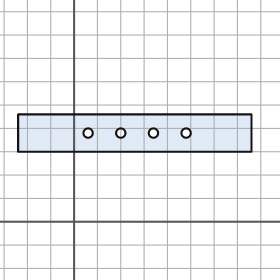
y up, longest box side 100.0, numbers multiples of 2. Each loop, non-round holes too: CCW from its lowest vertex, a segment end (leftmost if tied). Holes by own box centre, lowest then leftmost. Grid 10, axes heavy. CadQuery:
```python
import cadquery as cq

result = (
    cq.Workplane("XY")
    .moveTo(-24.0, 30.0)
    .lineTo(76.0, 30.0)
    .lineTo(76.0, 46.0)
    .lineTo(-24.0, 46.0)
    .close()
    .moveTo(6.0, 38.0)
    .circle(2.0)
    .moveTo(20.0, 38.0)
    .circle(2.0)
    .moveTo(34.0, 38.0)
    .circle(2.0)
    .moveTo(48.0, 38.0)
    .circle(2.0)
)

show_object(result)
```